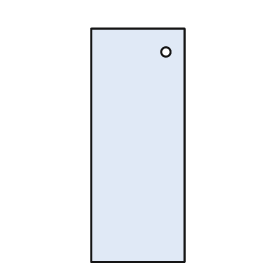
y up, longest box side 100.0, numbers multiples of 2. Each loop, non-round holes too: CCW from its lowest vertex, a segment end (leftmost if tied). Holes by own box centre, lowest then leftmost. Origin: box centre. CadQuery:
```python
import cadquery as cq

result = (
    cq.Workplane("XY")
    .moveTo(-20.0, -50.0)
    .lineTo(20.0, -50.0)
    .lineTo(20.0, 50.0)
    .lineTo(-20.0, 50.0)
    .close()
    .moveTo(12.0, 40.0)
    .circle(2.0)
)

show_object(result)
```